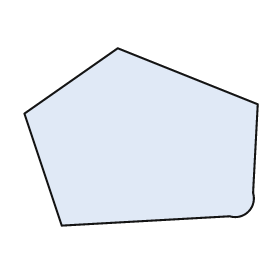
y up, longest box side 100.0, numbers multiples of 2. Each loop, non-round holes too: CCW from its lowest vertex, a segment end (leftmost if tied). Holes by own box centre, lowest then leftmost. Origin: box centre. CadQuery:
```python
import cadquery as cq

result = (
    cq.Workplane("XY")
    .moveTo(-34.0, -38.0)
    .lineTo(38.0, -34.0)
    .threePointArc((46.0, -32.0), (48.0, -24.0))
    .lineTo(50.0, 14.0)
    .lineTo(-10.0, 38.0)
    .lineTo(-50.0, 10.0)
    .close()
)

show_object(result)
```